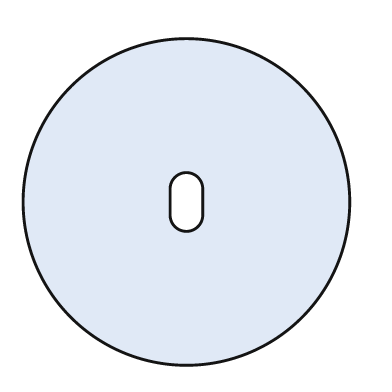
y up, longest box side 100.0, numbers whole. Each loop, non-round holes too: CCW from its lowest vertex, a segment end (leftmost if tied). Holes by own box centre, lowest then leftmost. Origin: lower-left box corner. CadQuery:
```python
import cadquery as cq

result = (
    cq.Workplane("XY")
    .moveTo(50.0, 50.0)
    .circle(50.0)
    .moveTo(45.0, 46.0)
    .threePointArc((50.0, 41.0), (55.0, 46.0))
    .lineTo(55.0, 54.0)
    .threePointArc((50.0, 59.0), (45.0, 54.0))
    .close()
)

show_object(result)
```